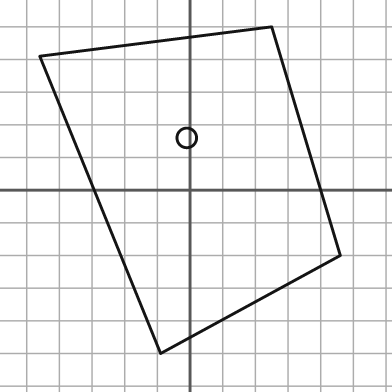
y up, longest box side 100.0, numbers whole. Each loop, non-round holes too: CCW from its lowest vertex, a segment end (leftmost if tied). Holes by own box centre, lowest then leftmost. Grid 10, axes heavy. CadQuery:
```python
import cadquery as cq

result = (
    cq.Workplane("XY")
    .moveTo(-9.0, -50.0)
    .lineTo(46.0, -20.0)
    .lineTo(25.0, 50.0)
    .lineTo(-46.0, 41.0)
    .close()
    .moveTo(-1.0, 16.0)
    .circle(3.0)
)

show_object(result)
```